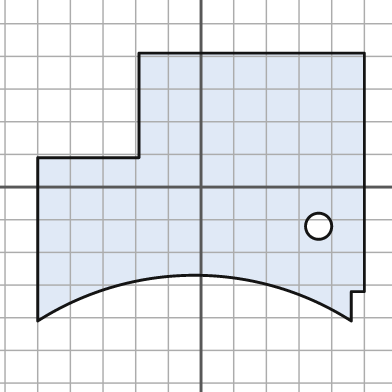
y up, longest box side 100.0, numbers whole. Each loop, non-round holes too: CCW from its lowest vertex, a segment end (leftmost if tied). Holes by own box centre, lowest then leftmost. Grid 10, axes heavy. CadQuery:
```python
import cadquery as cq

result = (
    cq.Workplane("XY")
    .moveTo(-50.0, -41.0)
    .threePointArc((-2.0, -27.0), (46.0, -41.0))
    .lineTo(46.0, -32.0)
    .lineTo(50.0, -32.0)
    .lineTo(50.0, 41.0)
    .lineTo(-19.0, 41.0)
    .lineTo(-19.0, 9.0)
    .lineTo(-50.0, 9.0)
    .close()
    .moveTo(36.0, -12.0)
    .circle(4.0)
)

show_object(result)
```